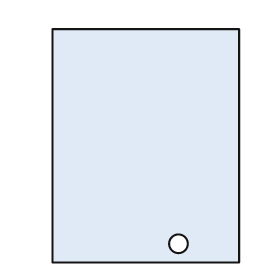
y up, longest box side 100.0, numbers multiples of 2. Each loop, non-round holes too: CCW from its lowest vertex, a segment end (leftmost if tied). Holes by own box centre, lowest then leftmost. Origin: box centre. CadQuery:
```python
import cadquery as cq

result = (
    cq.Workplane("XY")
    .moveTo(-40.0, -50.0)
    .lineTo(40.0, -50.0)
    .lineTo(40.0, 50.0)
    .lineTo(-40.0, 50.0)
    .close()
    .moveTo(14.0, -42.0)
    .circle(4.0)
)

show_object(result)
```